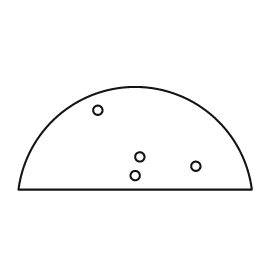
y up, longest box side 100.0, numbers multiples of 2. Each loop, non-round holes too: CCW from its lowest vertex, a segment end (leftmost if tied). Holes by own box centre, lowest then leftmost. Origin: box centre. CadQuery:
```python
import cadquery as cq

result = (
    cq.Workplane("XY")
    .moveTo(-50.0, -22.0)
    .lineTo(50.0, -22.0)
    .threePointArc((0.0, 22.0), (-50.0, -22.0))
    .close()
    .moveTo(0.0, -16.0)
    .circle(2.0)
    .moveTo(26.0, -12.0)
    .circle(2.0)
    .moveTo(2.0, -8.0)
    .circle(2.0)
    .moveTo(-16.0, 12.0)
    .circle(2.0)
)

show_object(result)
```